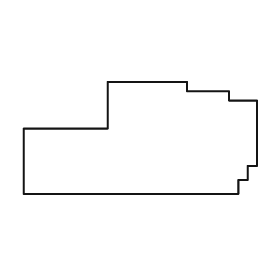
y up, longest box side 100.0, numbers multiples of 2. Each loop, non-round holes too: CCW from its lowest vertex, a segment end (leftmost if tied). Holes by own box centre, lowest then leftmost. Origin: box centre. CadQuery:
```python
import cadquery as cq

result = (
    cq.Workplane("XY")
    .moveTo(-50.0, -24.0)
    .lineTo(42.0, -24.0)
    .lineTo(42.0, -18.0)
    .lineTo(46.0, -18.0)
    .lineTo(46.0, -12.0)
    .lineTo(50.0, -12.0)
    .lineTo(50.0, 16.0)
    .lineTo(38.0, 16.0)
    .lineTo(38.0, 20.0)
    .lineTo(20.0, 20.0)
    .lineTo(20.0, 24.0)
    .lineTo(-14.0, 24.0)
    .lineTo(-14.0, 4.0)
    .lineTo(-50.0, 4.0)
    .close()
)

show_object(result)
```